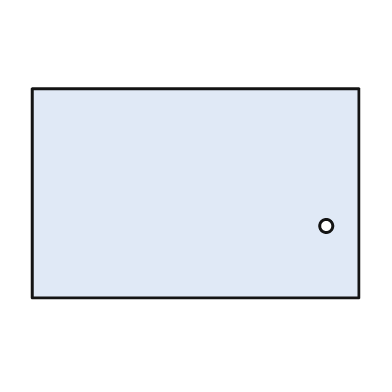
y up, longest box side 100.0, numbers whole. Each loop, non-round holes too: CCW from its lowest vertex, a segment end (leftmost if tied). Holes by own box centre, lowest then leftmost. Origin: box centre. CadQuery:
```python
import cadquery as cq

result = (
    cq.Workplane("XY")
    .moveTo(-50.0, -32.0)
    .lineTo(50.0, -32.0)
    .lineTo(50.0, 32.0)
    .lineTo(-50.0, 32.0)
    .close()
    .moveTo(40.0, -10.0)
    .circle(2.0)
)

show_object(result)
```